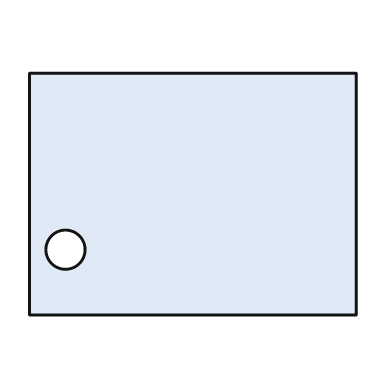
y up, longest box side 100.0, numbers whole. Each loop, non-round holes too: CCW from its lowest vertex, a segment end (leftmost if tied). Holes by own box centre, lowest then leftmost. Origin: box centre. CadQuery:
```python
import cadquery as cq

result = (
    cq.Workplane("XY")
    .moveTo(-50.0, -37.0)
    .lineTo(50.0, -37.0)
    .lineTo(50.0, 37.0)
    .lineTo(-50.0, 37.0)
    .close()
    .moveTo(-39.0, -17.0)
    .circle(6.0)
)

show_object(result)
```